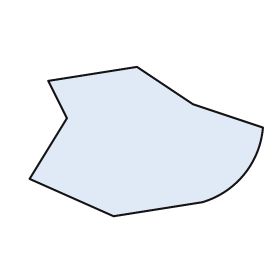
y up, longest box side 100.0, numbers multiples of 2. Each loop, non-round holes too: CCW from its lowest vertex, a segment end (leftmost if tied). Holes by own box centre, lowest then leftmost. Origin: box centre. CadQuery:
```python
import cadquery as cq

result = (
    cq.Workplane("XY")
    .moveTo(-14.0, -32.0)
    .lineTo(24.0, -26.0)
    .threePointArc((42.0, -14.0), (50.0, 6.0))
    .lineTo(20.0, 16.0)
    .lineTo(-4.0, 32.0)
    .lineTo(-42.0, 26.0)
    .lineTo(-34.0, 10.0)
    .lineTo(-50.0, -16.0)
    .close()
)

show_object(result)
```